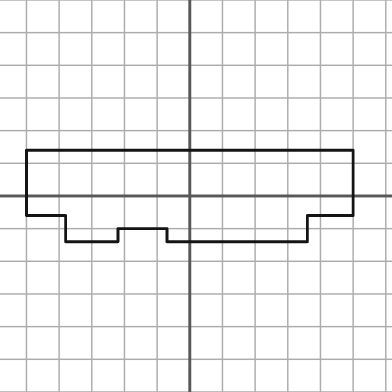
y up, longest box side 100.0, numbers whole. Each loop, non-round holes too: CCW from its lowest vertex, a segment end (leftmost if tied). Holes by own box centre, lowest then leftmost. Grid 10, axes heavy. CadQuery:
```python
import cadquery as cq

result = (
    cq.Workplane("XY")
    .moveTo(-38.0, -14.0)
    .lineTo(-22.0, -14.0)
    .lineTo(-22.0, -10.0)
    .lineTo(-7.0, -10.0)
    .lineTo(-7.0, -14.0)
    .lineTo(36.0, -14.0)
    .lineTo(36.0, -6.0)
    .lineTo(50.0, -6.0)
    .lineTo(50.0, 14.0)
    .lineTo(-50.0, 14.0)
    .lineTo(-50.0, -6.0)
    .lineTo(-38.0, -6.0)
    .close()
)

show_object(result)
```